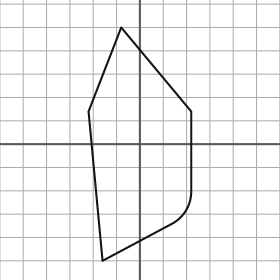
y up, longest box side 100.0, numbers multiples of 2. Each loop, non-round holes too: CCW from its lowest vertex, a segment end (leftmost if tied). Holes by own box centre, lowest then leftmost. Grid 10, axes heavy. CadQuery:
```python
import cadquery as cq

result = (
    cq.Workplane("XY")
    .moveTo(-16.0, -50.0)
    .lineTo(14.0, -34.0)
    .threePointArc((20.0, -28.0), (22.0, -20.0))
    .lineTo(22.0, 14.0)
    .lineTo(-8.0, 50.0)
    .lineTo(-22.0, 14.0)
    .close()
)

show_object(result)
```